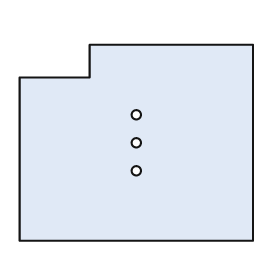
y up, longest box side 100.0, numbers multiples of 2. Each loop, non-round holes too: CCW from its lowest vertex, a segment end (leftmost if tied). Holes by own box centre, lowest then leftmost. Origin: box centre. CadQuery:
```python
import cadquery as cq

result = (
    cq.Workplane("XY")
    .moveTo(-50.0, -42.0)
    .lineTo(50.0, -42.0)
    .lineTo(50.0, 42.0)
    .lineTo(-20.0, 42.0)
    .lineTo(-20.0, 28.0)
    .lineTo(-50.0, 28.0)
    .close()
    .moveTo(0.0, -12.0)
    .circle(2.0)
    .moveTo(0.0, 0.0)
    .circle(2.0)
    .moveTo(0.0, 12.0)
    .circle(2.0)
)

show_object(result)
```